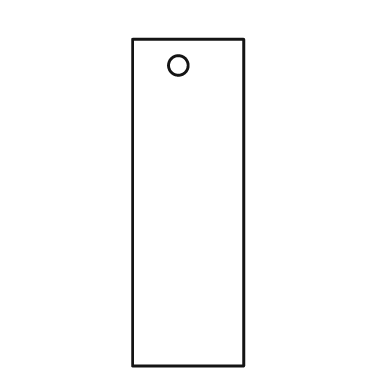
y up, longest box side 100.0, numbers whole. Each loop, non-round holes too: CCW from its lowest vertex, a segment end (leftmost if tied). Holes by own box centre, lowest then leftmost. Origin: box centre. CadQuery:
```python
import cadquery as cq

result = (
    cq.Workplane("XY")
    .moveTo(-17.0, -50.0)
    .lineTo(17.0, -50.0)
    .lineTo(17.0, 50.0)
    .lineTo(-17.0, 50.0)
    .close()
    .moveTo(-3.0, 42.0)
    .circle(3.0)
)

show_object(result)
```